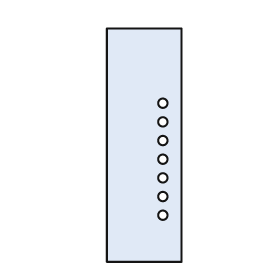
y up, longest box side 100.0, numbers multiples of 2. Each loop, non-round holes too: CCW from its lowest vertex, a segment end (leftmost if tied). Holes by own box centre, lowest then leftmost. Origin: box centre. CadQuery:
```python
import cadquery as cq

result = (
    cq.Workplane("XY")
    .moveTo(-16.0, -50.0)
    .lineTo(16.0, -50.0)
    .lineTo(16.0, 50.0)
    .lineTo(-16.0, 50.0)
    .close()
    .moveTo(8.0, -30.0)
    .circle(2.0)
    .moveTo(8.0, -22.0)
    .circle(2.0)
    .moveTo(8.0, -14.0)
    .circle(2.0)
    .moveTo(8.0, -6.0)
    .circle(2.0)
    .moveTo(8.0, 2.0)
    .circle(2.0)
    .moveTo(8.0, 10.0)
    .circle(2.0)
    .moveTo(8.0, 18.0)
    .circle(2.0)
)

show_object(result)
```